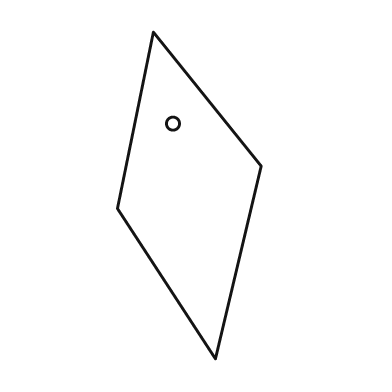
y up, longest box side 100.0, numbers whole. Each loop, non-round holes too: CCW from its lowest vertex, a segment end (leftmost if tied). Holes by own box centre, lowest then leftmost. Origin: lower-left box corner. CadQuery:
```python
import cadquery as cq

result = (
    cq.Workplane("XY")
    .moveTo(30.0, 0.0)
    .lineTo(44.0, 59.0)
    .lineTo(11.0, 100.0)
    .lineTo(0.0, 46.0)
    .close()
    .moveTo(17.0, 72.0)
    .circle(2.0)
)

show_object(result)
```